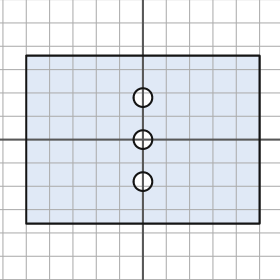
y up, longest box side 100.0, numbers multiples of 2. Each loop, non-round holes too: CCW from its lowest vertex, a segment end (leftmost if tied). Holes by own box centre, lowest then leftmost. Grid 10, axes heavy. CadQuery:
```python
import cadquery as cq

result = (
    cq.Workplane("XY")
    .moveTo(-50.0, -36.0)
    .lineTo(50.0, -36.0)
    .lineTo(50.0, 36.0)
    .lineTo(-50.0, 36.0)
    .close()
    .moveTo(0.0, -18.0)
    .circle(4.0)
    .moveTo(0.0, 0.0)
    .circle(4.0)
    .moveTo(0.0, 18.0)
    .circle(4.0)
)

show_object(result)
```